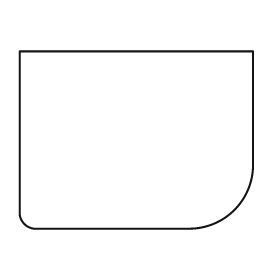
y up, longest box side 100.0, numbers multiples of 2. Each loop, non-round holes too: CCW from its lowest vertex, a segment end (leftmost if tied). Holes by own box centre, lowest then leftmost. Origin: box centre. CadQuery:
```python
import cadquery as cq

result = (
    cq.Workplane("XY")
    .moveTo(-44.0, -38.0)
    .lineTo(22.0, -38.0)
    .threePointArc((42.0, -30.0), (50.0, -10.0))
    .lineTo(50.0, 38.0)
    .lineTo(-50.0, 38.0)
    .lineTo(-50.0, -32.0)
    .threePointArc((-48.0, -36.0), (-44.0, -38.0))
    .close()
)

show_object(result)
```